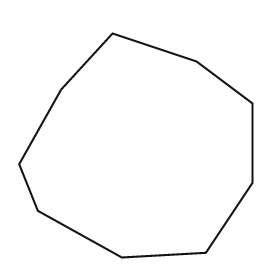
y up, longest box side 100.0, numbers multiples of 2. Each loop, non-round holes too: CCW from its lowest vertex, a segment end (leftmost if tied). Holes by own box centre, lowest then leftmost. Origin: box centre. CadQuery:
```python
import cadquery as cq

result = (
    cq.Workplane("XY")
    .moveTo(-6.0, -48.0)
    .lineTo(30.0, -46.0)
    .lineTo(50.0, -16.0)
    .lineTo(50.0, 18.0)
    .lineTo(26.0, 36.0)
    .lineTo(-10.0, 48.0)
    .lineTo(-32.0, 24.0)
    .lineTo(-50.0, -8.0)
    .lineTo(-42.0, -28.0)
    .close()
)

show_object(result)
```